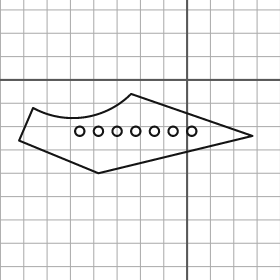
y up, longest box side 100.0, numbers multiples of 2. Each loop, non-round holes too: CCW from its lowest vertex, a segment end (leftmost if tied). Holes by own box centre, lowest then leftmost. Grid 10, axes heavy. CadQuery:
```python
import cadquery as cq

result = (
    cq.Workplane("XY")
    .moveTo(-38.0, -40.0)
    .lineTo(28.0, -24.0)
    .lineTo(-24.0, -6.0)
    .threePointArc((-44.0, -16.0), (-66.0, -12.0))
    .lineTo(-72.0, -26.0)
    .close()
    .moveTo(-46.0, -22.0)
    .circle(2.0)
    .moveTo(-38.0, -22.0)
    .circle(2.0)
    .moveTo(-30.0, -22.0)
    .circle(2.0)
    .moveTo(-22.0, -22.0)
    .circle(2.0)
    .moveTo(-14.0, -22.0)
    .circle(2.0)
    .moveTo(-6.0, -22.0)
    .circle(2.0)
    .moveTo(2.0, -22.0)
    .circle(2.0)
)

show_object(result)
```